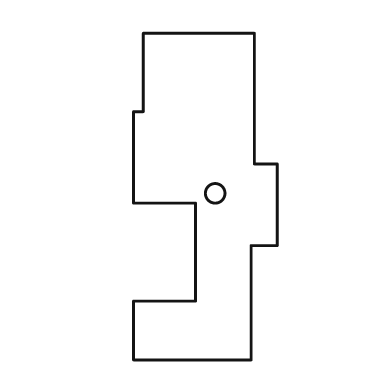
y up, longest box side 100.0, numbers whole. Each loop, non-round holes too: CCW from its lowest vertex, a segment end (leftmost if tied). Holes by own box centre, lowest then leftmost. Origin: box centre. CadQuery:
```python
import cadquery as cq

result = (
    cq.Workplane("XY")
    .moveTo(-22.0, -50.0)
    .lineTo(14.0, -50.0)
    .lineTo(14.0, -15.0)
    .lineTo(22.0, -15.0)
    .lineTo(22.0, 10.0)
    .lineTo(15.0, 10.0)
    .lineTo(15.0, 50.0)
    .lineTo(-19.0, 50.0)
    .lineTo(-19.0, 26.0)
    .lineTo(-22.0, 26.0)
    .lineTo(-22.0, -2.0)
    .lineTo(-3.0, -2.0)
    .lineTo(-3.0, -32.0)
    .lineTo(-22.0, -32.0)
    .close()
    .moveTo(3.0, 1.0)
    .circle(3.0)
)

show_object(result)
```